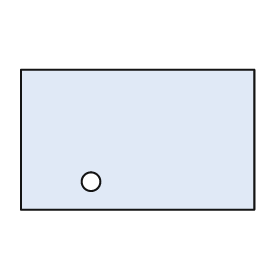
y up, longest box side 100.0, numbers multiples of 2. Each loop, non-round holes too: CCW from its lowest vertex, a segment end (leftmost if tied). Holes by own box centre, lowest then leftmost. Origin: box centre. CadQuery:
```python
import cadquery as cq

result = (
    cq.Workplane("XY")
    .moveTo(-50.0, -30.0)
    .lineTo(50.0, -30.0)
    .lineTo(50.0, 30.0)
    .lineTo(-50.0, 30.0)
    .close()
    .moveTo(-20.0, -18.0)
    .circle(4.0)
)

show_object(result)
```